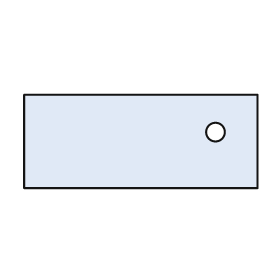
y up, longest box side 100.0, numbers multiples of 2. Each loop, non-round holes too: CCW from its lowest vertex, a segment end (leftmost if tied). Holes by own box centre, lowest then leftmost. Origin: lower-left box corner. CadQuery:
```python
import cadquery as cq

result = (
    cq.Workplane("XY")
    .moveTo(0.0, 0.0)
    .lineTo(100.0, 0.0)
    .lineTo(100.0, 40.0)
    .lineTo(0.0, 40.0)
    .close()
    .moveTo(82.0, 24.0)
    .circle(4.0)
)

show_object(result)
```